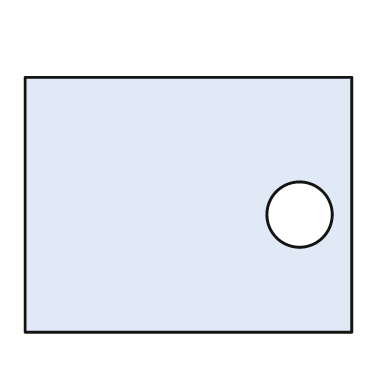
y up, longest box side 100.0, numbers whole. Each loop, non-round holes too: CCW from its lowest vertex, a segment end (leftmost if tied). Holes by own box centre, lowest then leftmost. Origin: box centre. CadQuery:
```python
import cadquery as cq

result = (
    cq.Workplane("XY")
    .moveTo(-50.0, -39.0)
    .lineTo(50.0, -39.0)
    .lineTo(50.0, 39.0)
    .lineTo(-50.0, 39.0)
    .close()
    .moveTo(34.0, -3.0)
    .circle(10.0)
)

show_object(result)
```